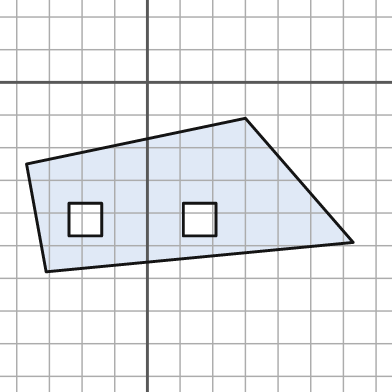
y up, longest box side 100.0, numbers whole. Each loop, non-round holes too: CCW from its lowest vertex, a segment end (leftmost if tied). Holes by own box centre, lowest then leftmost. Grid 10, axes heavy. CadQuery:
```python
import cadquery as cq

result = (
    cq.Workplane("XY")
    .moveTo(-31.0, -58.0)
    .lineTo(63.0, -49.0)
    .lineTo(30.0, -11.0)
    .lineTo(-37.0, -25.0)
    .close()
    .moveTo(-24.0, -47.0)
    .lineTo(-14.0, -47.0)
    .lineTo(-14.0, -37.0)
    .lineTo(-24.0, -37.0)
    .close()
    .moveTo(11.0, -47.0)
    .lineTo(21.0, -47.0)
    .lineTo(21.0, -37.0)
    .lineTo(11.0, -37.0)
    .close()
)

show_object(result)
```